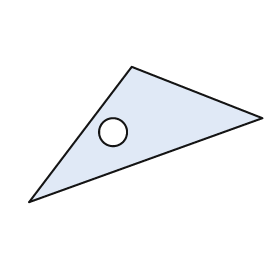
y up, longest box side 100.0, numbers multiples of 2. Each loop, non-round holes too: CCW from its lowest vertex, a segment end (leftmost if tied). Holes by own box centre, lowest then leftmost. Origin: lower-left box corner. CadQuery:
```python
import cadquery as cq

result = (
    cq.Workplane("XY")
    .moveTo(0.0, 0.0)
    .lineTo(100.0, 36.0)
    .lineTo(44.0, 58.0)
    .close()
    .moveTo(36.0, 30.0)
    .circle(6.0)
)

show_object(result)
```